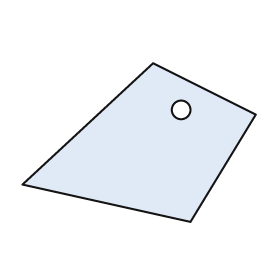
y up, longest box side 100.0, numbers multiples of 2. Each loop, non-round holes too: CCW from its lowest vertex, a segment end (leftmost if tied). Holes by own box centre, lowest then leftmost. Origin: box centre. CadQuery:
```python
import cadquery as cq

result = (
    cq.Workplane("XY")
    .moveTo(22.0, -34.0)
    .lineTo(50.0, 12.0)
    .lineTo(6.0, 34.0)
    .lineTo(-50.0, -18.0)
    .close()
    .moveTo(18.0, 14.0)
    .circle(4.0)
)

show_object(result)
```